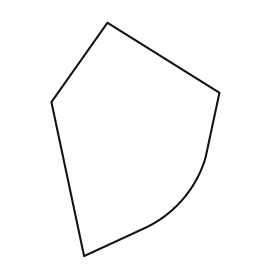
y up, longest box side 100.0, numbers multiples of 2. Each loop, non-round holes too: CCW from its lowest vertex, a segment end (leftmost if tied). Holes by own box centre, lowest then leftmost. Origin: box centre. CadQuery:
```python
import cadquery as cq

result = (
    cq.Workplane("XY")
    .moveTo(-22.0, -50.0)
    .lineTo(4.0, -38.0)
    .threePointArc((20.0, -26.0), (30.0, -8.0))
    .lineTo(36.0, 20.0)
    .lineTo(-12.0, 50.0)
    .lineTo(-36.0, 16.0)
    .close()
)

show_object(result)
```